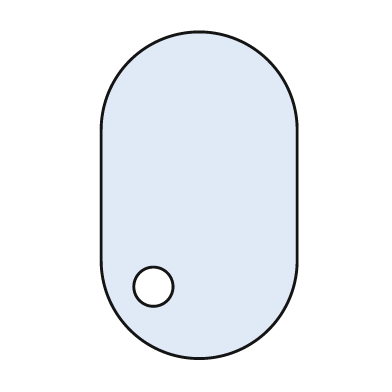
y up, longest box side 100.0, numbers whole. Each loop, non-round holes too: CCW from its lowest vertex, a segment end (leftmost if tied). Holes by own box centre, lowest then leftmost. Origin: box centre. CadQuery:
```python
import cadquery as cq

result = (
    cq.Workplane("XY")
    .moveTo(-30.0, -20.0)
    .threePointArc((0.0, -50.0), (30.0, -20.0))
    .lineTo(30.0, 20.0)
    .threePointArc((0.0, 50.0), (-30.0, 20.0))
    .close()
    .moveTo(-14.0, -28.0)
    .circle(6.0)
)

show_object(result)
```